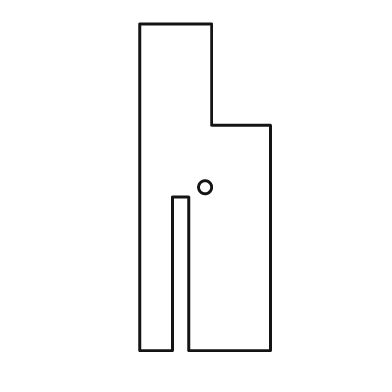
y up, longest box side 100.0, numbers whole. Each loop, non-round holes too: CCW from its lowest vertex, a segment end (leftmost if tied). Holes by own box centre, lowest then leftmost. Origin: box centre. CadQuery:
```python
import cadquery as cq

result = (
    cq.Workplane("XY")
    .moveTo(-20.0, -50.0)
    .lineTo(-10.0, -50.0)
    .lineTo(-10.0, -3.0)
    .lineTo(-5.0, -3.0)
    .lineTo(-5.0, -50.0)
    .lineTo(20.0, -50.0)
    .lineTo(20.0, 19.0)
    .lineTo(2.0, 19.0)
    .lineTo(2.0, 50.0)
    .lineTo(-20.0, 50.0)
    .close()
    .moveTo(0.0, 0.0)
    .circle(2.0)
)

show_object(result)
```